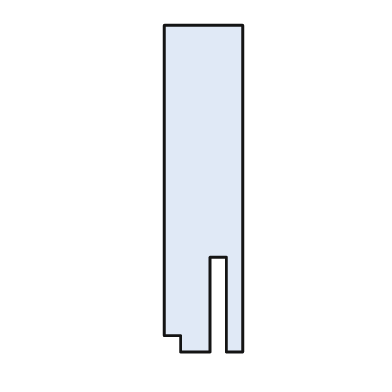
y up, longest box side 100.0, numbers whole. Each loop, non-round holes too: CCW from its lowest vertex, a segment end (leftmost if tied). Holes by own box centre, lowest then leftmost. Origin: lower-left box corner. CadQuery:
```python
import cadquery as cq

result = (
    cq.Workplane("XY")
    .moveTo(5.0, 0.0)
    .lineTo(14.0, 0.0)
    .lineTo(14.0, 29.0)
    .lineTo(19.0, 29.0)
    .lineTo(19.0, 0.0)
    .lineTo(24.0, 0.0)
    .lineTo(24.0, 100.0)
    .lineTo(0.0, 100.0)
    .lineTo(0.0, 5.0)
    .lineTo(5.0, 5.0)
    .close()
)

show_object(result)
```